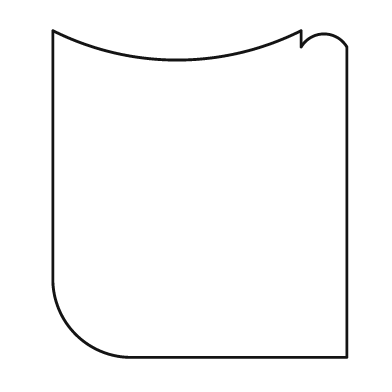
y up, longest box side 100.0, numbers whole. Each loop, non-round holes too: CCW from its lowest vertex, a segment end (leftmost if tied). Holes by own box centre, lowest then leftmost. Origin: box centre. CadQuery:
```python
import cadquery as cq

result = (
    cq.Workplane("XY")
    .moveTo(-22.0, -50.0)
    .lineTo(45.0, -50.0)
    .lineTo(45.0, 45.0)
    .threePointArc((38.0, 49.0), (31.0, 45.0))
    .lineTo(31.0, 50.0)
    .threePointArc((-7.0, 41.0), (-45.0, 50.0))
    .lineTo(-45.0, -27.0)
    .threePointArc((-38.0, -43.0), (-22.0, -50.0))
    .close()
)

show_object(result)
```